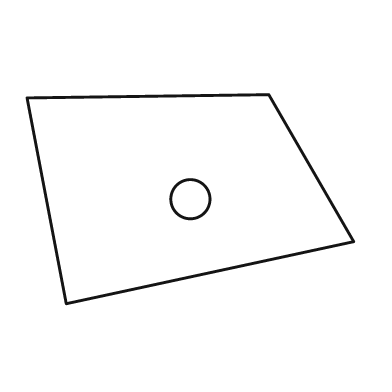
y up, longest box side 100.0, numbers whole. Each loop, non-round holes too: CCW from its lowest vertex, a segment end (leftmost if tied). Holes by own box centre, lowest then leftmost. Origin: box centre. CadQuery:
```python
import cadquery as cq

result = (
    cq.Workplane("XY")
    .moveTo(-38.0, -32.0)
    .lineTo(50.0, -13.0)
    .lineTo(24.0, 32.0)
    .lineTo(-50.0, 31.0)
    .close()
    .moveTo(0.0, 0.0)
    .circle(6.0)
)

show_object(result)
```